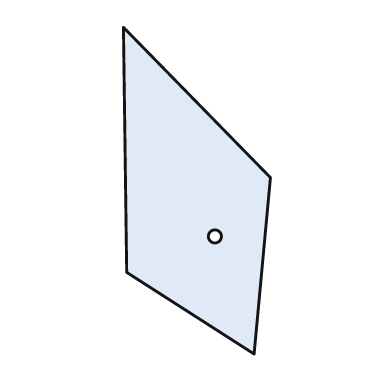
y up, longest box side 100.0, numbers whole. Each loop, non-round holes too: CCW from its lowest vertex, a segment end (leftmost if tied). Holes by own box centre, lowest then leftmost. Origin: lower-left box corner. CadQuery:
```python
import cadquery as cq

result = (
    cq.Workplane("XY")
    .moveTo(40.0, 0.0)
    .lineTo(45.0, 54.0)
    .lineTo(0.0, 100.0)
    .lineTo(1.0, 25.0)
    .close()
    .moveTo(28.0, 36.0)
    .circle(2.0)
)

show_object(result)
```